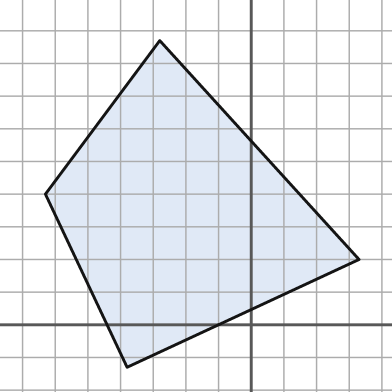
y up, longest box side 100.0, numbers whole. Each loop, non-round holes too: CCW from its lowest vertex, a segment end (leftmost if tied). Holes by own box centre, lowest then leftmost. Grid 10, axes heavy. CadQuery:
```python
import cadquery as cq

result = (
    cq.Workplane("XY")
    .moveTo(-38.0, -13.0)
    .lineTo(33.0, 20.0)
    .lineTo(-28.0, 87.0)
    .lineTo(-63.0, 40.0)
    .close()
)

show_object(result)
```